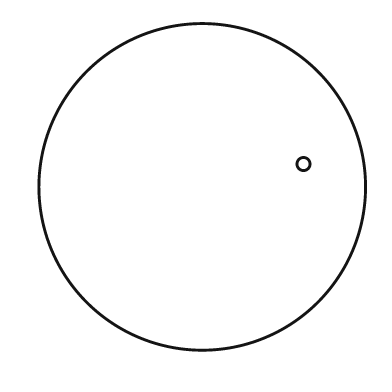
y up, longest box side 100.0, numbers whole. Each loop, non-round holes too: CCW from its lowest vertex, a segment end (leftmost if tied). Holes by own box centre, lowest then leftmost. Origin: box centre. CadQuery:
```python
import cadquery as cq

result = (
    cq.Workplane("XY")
    .moveTo(0.0, 0.0)
    .circle(50.0)
    .moveTo(31.0, 7.0)
    .circle(2.0)
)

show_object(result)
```